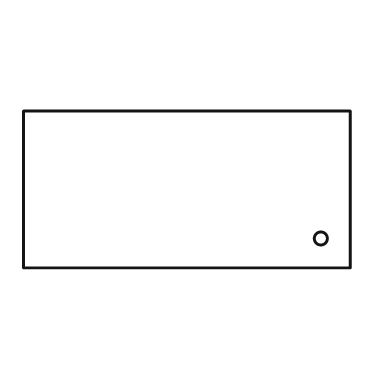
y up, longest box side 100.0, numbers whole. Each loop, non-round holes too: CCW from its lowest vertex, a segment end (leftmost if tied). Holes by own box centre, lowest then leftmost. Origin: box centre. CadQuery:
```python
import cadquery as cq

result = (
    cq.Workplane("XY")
    .moveTo(-50.0, -24.0)
    .lineTo(50.0, -24.0)
    .lineTo(50.0, 24.0)
    .lineTo(-50.0, 24.0)
    .close()
    .moveTo(41.0, -15.0)
    .circle(2.0)
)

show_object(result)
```